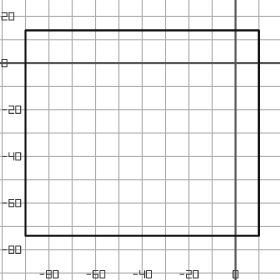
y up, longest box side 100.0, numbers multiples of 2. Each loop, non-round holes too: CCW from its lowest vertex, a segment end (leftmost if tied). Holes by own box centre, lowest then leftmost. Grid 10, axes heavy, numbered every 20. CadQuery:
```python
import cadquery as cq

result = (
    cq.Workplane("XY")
    .moveTo(-90.0, -74.0)
    .lineTo(10.0, -74.0)
    .lineTo(10.0, 14.0)
    .lineTo(-90.0, 14.0)
    .close()
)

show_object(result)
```